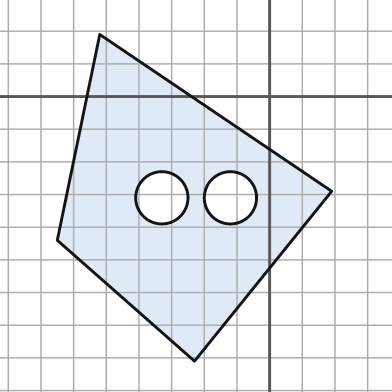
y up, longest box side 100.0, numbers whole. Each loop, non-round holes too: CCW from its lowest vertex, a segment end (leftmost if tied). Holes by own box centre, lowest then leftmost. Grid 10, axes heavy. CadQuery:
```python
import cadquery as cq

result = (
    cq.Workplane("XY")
    .moveTo(-23.0, -81.0)
    .lineTo(19.0, -29.0)
    .lineTo(-52.0, 19.0)
    .lineTo(-65.0, -44.0)
    .close()
    .moveTo(-33.0, -31.0)
    .circle(8.0)
    .moveTo(-12.0, -31.0)
    .circle(8.0)
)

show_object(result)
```